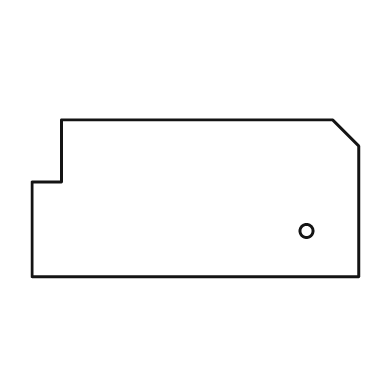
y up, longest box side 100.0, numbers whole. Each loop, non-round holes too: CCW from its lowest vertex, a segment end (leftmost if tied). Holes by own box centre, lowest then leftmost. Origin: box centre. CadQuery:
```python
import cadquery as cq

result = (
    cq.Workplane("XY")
    .moveTo(-50.0, -24.0)
    .lineTo(50.0, -24.0)
    .lineTo(50.0, 16.0)
    .lineTo(42.0, 24.0)
    .lineTo(-41.0, 24.0)
    .lineTo(-41.0, 5.0)
    .lineTo(-50.0, 5.0)
    .close()
    .moveTo(34.0, -10.0)
    .circle(2.0)
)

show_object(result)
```